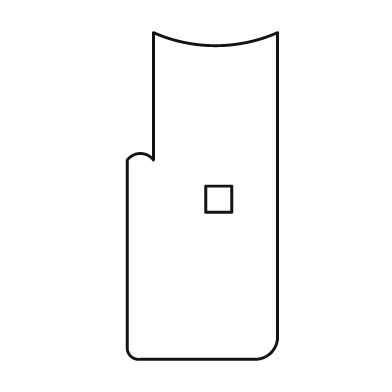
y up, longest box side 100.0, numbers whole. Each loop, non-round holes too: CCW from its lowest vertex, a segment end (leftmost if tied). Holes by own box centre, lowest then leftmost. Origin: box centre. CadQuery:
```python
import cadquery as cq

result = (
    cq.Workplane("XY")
    .moveTo(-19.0, -50.0)
    .lineTo(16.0, -50.0)
    .threePointArc((21.0, -48.0), (23.0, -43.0))
    .lineTo(23.0, 50.0)
    .threePointArc((4.0, 46.0), (-15.0, 50.0))
    .lineTo(-15.0, 11.0)
    .threePointArc((-19.0, 13.0), (-23.0, 11.0))
    .lineTo(-23.0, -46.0)
    .threePointArc((-22.0, -49.0), (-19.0, -50.0))
    .close()
    .moveTo(1.0, -5.0)
    .lineTo(9.0, -5.0)
    .lineTo(9.0, 3.0)
    .lineTo(1.0, 3.0)
    .close()
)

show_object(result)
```